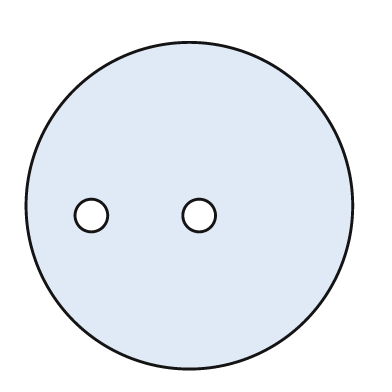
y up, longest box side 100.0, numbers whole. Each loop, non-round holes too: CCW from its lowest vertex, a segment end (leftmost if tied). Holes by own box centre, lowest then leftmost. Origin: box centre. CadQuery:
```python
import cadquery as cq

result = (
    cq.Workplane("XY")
    .moveTo(0.0, 0.0)
    .circle(50.0)
    .moveTo(-30.0, -3.0)
    .circle(5.0)
    .moveTo(3.0, -3.0)
    .circle(5.0)
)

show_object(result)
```